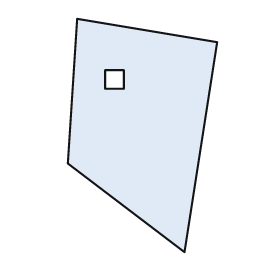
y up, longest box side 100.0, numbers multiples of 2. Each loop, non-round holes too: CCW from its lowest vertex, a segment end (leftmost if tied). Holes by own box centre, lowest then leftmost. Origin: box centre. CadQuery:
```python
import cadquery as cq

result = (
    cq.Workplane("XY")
    .moveTo(18.0, -50.0)
    .lineTo(32.0, 40.0)
    .lineTo(-28.0, 50.0)
    .lineTo(-32.0, -12.0)
    .close()
    .moveTo(-16.0, 20.0)
    .lineTo(-8.0, 20.0)
    .lineTo(-8.0, 28.0)
    .lineTo(-16.0, 28.0)
    .close()
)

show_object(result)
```